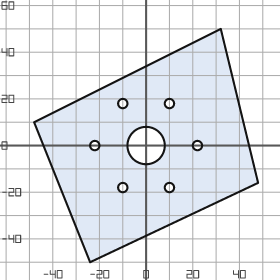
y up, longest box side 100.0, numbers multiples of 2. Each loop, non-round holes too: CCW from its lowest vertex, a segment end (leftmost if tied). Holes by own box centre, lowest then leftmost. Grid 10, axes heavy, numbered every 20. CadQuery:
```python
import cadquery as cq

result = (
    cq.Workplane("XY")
    .moveTo(-24.0, -50.0)
    .lineTo(48.0, -16.0)
    .lineTo(32.0, 50.0)
    .lineTo(-48.0, 10.0)
    .close()
    .moveTo(-10.0, -18.0)
    .circle(2.0)
    .moveTo(10.0, -18.0)
    .circle(2.0)
    .moveTo(-22.0, 0.0)
    .circle(2.0)
    .moveTo(0.0, 0.0)
    .circle(8.0)
    .moveTo(22.0, 0.0)
    .circle(2.0)
    .moveTo(-10.0, 18.0)
    .circle(2.0)
    .moveTo(10.0, 18.0)
    .circle(2.0)
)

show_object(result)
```